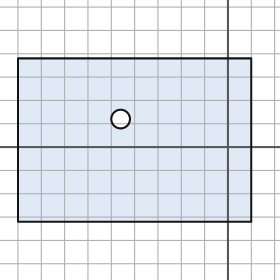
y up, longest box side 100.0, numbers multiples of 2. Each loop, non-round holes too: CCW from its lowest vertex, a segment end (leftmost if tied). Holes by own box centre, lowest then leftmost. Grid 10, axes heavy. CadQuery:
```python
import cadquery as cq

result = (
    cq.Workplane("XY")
    .moveTo(-90.0, -32.0)
    .lineTo(10.0, -32.0)
    .lineTo(10.0, 38.0)
    .lineTo(-90.0, 38.0)
    .close()
    .moveTo(-46.0, 12.0)
    .circle(4.0)
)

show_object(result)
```